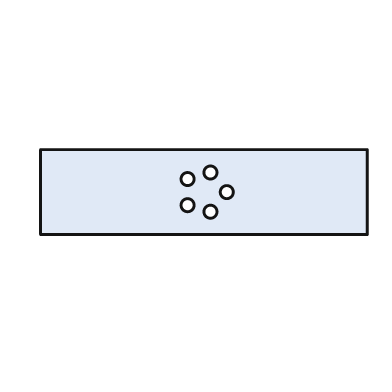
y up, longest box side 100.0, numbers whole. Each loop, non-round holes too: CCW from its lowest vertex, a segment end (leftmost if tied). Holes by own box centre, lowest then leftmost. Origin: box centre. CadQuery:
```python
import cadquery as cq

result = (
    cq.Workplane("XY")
    .moveTo(-50.0, -13.0)
    .lineTo(50.0, -13.0)
    .lineTo(50.0, 13.0)
    .lineTo(-50.0, 13.0)
    .close()
    .moveTo(2.0, -6.0)
    .circle(2.0)
    .moveTo(-5.0, -4.0)
    .circle(2.0)
    .moveTo(7.0, 0.0)
    .circle(2.0)
    .moveTo(-5.0, 4.0)
    .circle(2.0)
    .moveTo(2.0, 6.0)
    .circle(2.0)
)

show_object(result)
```